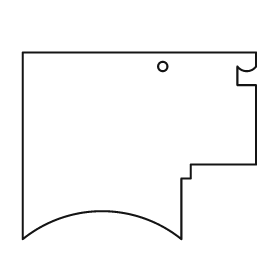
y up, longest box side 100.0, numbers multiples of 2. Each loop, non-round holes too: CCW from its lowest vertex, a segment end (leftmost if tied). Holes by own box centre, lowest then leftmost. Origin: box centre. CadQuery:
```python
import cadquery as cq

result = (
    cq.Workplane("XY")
    .moveTo(-50.0, -40.0)
    .threePointArc((-16.0, -28.0), (18.0, -40.0))
    .lineTo(18.0, -14.0)
    .lineTo(22.0, -14.0)
    .lineTo(22.0, -8.0)
    .lineTo(50.0, -8.0)
    .lineTo(50.0, 26.0)
    .lineTo(42.0, 26.0)
    .lineTo(42.0, 34.0)
    .threePointArc((46.0, 32.0), (50.0, 34.0))
    .lineTo(50.0, 40.0)
    .lineTo(-50.0, 40.0)
    .close()
    .moveTo(10.0, 34.0)
    .circle(2.0)
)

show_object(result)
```